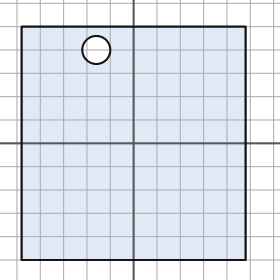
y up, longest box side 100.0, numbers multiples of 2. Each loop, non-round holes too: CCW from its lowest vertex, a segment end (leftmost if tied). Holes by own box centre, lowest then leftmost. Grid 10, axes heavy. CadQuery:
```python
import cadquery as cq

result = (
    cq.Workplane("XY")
    .moveTo(-48.0, -50.0)
    .lineTo(48.0, -50.0)
    .lineTo(48.0, 50.0)
    .lineTo(-48.0, 50.0)
    .close()
    .moveTo(-16.0, 40.0)
    .circle(6.0)
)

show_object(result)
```